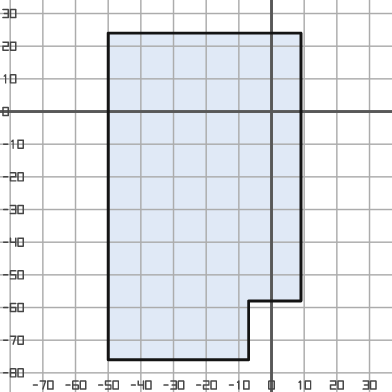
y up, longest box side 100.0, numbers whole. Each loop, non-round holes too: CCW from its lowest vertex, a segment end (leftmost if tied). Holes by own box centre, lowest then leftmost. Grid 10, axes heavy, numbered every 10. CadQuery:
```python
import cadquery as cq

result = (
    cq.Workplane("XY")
    .moveTo(-50.0, -76.0)
    .lineTo(-7.0, -76.0)
    .lineTo(-7.0, -58.0)
    .lineTo(9.0, -58.0)
    .lineTo(9.0, 24.0)
    .lineTo(-50.0, 24.0)
    .close()
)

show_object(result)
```